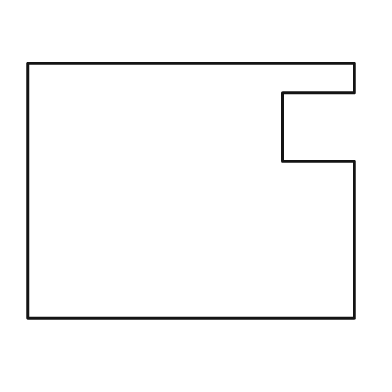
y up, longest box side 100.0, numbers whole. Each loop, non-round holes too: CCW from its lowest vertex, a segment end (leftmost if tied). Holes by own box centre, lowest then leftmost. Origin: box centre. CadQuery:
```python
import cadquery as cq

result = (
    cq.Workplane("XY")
    .moveTo(-50.0, -39.0)
    .lineTo(50.0, -39.0)
    .lineTo(50.0, 9.0)
    .lineTo(28.0, 9.0)
    .lineTo(28.0, 30.0)
    .lineTo(50.0, 30.0)
    .lineTo(50.0, 39.0)
    .lineTo(-50.0, 39.0)
    .close()
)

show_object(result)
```